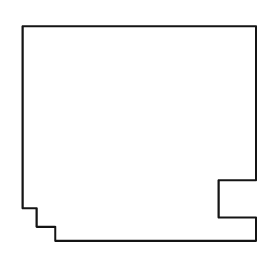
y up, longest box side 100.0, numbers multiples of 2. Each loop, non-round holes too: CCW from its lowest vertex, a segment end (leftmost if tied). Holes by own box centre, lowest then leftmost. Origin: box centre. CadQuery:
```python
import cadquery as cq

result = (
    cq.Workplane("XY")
    .moveTo(-36.0, -46.0)
    .lineTo(50.0, -46.0)
    .lineTo(50.0, -36.0)
    .lineTo(34.0, -36.0)
    .lineTo(34.0, -20.0)
    .lineTo(50.0, -20.0)
    .lineTo(50.0, 46.0)
    .lineTo(-50.0, 46.0)
    .lineTo(-50.0, -32.0)
    .lineTo(-44.0, -32.0)
    .lineTo(-44.0, -40.0)
    .lineTo(-36.0, -40.0)
    .close()
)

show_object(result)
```